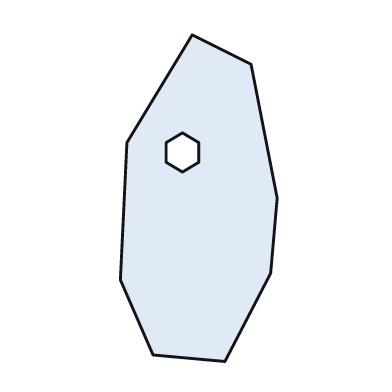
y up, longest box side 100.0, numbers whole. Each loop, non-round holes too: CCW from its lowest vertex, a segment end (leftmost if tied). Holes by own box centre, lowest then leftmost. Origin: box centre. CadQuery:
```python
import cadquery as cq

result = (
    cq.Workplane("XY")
    .moveTo(8.0, -50.0)
    .lineTo(22.0, -23.0)
    .lineTo(24.0, 0.0)
    .lineTo(16.0, 41.0)
    .lineTo(-2.0, 50.0)
    .lineTo(-22.0, 17.0)
    .lineTo(-24.0, -25.0)
    .lineTo(-14.0, -48.0)
    .close()
    .moveTo(-5.0, 8.0)
    .lineTo(0.0, 11.0)
    .lineTo(0.0, 17.0)
    .lineTo(-5.0, 20.0)
    .lineTo(-10.0, 17.0)
    .lineTo(-10.0, 11.0)
    .close()
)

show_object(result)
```